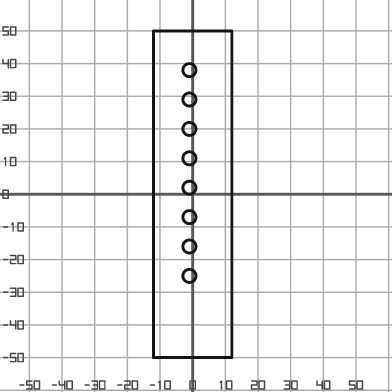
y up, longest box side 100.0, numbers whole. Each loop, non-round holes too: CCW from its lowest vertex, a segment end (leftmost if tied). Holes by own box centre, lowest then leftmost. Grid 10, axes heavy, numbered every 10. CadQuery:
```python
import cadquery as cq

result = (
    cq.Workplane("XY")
    .moveTo(-12.0, -50.0)
    .lineTo(12.0, -50.0)
    .lineTo(12.0, 50.0)
    .lineTo(-12.0, 50.0)
    .close()
    .moveTo(-1.0, -25.0)
    .circle(2.0)
    .moveTo(-1.0, -16.0)
    .circle(2.0)
    .moveTo(-1.0, -7.0)
    .circle(2.0)
    .moveTo(-1.0, 2.0)
    .circle(2.0)
    .moveTo(-1.0, 11.0)
    .circle(2.0)
    .moveTo(-1.0, 20.0)
    .circle(2.0)
    .moveTo(-1.0, 29.0)
    .circle(2.0)
    .moveTo(-1.0, 38.0)
    .circle(2.0)
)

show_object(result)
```